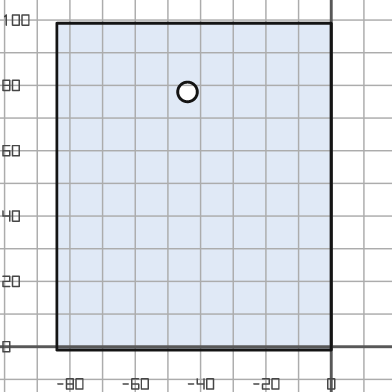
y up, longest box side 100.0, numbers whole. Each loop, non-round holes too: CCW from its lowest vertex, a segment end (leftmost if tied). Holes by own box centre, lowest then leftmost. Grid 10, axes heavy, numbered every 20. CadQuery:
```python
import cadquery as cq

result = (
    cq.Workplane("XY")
    .moveTo(-84.0, -1.0)
    .lineTo(0.0, -1.0)
    .lineTo(0.0, 99.0)
    .lineTo(-84.0, 99.0)
    .close()
    .moveTo(-44.0, 78.0)
    .circle(3.0)
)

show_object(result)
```